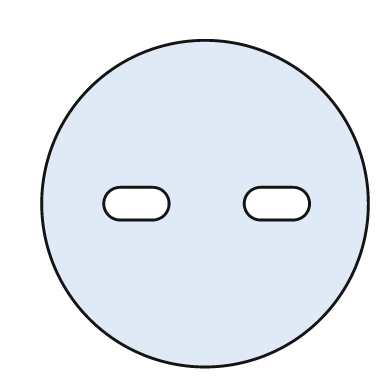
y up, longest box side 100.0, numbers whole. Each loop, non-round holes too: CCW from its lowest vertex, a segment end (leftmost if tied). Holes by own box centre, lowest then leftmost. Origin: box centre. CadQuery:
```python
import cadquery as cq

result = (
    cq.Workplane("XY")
    .moveTo(0.0, 0.0)
    .circle(50.0)
    .moveTo(-26.0, -5.0)
    .lineTo(-16.0, -5.0)
    .threePointArc((-11.0, 0.0), (-16.0, 5.0))
    .lineTo(-26.0, 5.0)
    .threePointArc((-31.0, 0.0), (-26.0, -5.0))
    .close()
    .moveTo(17.0, -5.0)
    .lineTo(27.0, -5.0)
    .threePointArc((32.0, 0.0), (27.0, 5.0))
    .lineTo(17.0, 5.0)
    .threePointArc((12.0, 0.0), (17.0, -5.0))
    .close()
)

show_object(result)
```